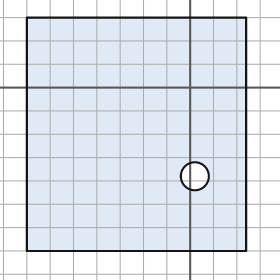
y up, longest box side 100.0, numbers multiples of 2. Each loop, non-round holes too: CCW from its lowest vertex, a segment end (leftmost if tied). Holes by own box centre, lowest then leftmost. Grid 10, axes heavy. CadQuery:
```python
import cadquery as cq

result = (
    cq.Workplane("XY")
    .moveTo(-70.0, -70.0)
    .lineTo(24.0, -70.0)
    .lineTo(24.0, 30.0)
    .lineTo(-70.0, 30.0)
    .close()
    .moveTo(2.0, -38.0)
    .circle(6.0)
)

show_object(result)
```